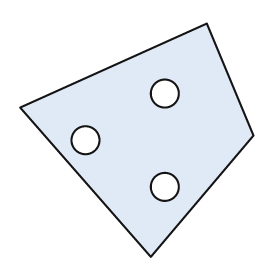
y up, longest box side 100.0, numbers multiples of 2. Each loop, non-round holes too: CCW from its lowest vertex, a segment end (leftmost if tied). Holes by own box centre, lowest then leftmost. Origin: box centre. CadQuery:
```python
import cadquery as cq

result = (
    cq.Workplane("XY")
    .moveTo(6.0, -50.0)
    .lineTo(50.0, 2.0)
    .lineTo(30.0, 50.0)
    .lineTo(-50.0, 14.0)
    .close()
    .moveTo(12.0, -20.0)
    .circle(6.0)
    .moveTo(-22.0, 0.0)
    .circle(6.0)
    .moveTo(12.0, 20.0)
    .circle(6.0)
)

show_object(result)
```